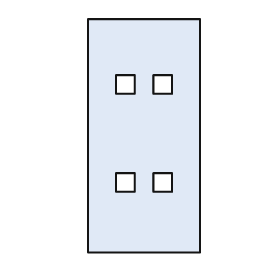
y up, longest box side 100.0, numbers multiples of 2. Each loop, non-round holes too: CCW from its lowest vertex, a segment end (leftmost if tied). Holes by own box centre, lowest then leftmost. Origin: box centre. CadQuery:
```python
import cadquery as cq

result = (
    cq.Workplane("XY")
    .moveTo(-24.0, -50.0)
    .lineTo(24.0, -50.0)
    .lineTo(24.0, 50.0)
    .lineTo(-24.0, 50.0)
    .close()
    .moveTo(-12.0, -24.0)
    .lineTo(-4.0, -24.0)
    .lineTo(-4.0, -16.0)
    .lineTo(-12.0, -16.0)
    .close()
    .moveTo(4.0, -24.0)
    .lineTo(12.0, -24.0)
    .lineTo(12.0, -16.0)
    .lineTo(4.0, -16.0)
    .close()
    .moveTo(-12.0, 18.0)
    .lineTo(-4.0, 18.0)
    .lineTo(-4.0, 26.0)
    .lineTo(-12.0, 26.0)
    .close()
    .moveTo(4.0, 18.0)
    .lineTo(12.0, 18.0)
    .lineTo(12.0, 26.0)
    .lineTo(4.0, 26.0)
    .close()
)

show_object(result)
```